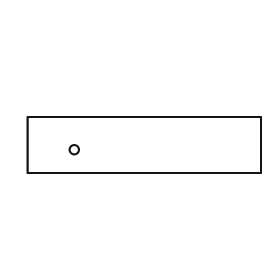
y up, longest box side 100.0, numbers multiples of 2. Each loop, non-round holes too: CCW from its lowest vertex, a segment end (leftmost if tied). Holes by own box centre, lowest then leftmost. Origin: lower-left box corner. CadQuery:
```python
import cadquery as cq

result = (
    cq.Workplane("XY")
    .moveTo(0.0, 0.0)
    .lineTo(100.0, 0.0)
    .lineTo(100.0, 24.0)
    .lineTo(0.0, 24.0)
    .close()
    .moveTo(20.0, 10.0)
    .circle(2.0)
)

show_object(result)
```